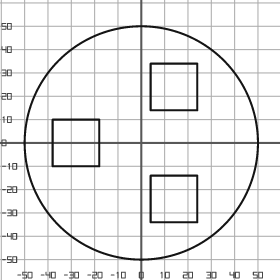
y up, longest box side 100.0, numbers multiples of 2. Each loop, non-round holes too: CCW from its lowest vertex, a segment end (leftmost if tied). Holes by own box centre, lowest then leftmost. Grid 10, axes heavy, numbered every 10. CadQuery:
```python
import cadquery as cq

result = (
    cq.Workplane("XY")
    .moveTo(0.0, 0.0)
    .circle(50.0)
    .moveTo(4.0, -34.0)
    .lineTo(24.0, -34.0)
    .lineTo(24.0, -14.0)
    .lineTo(4.0, -14.0)
    .close()
    .moveTo(-38.0, -10.0)
    .lineTo(-18.0, -10.0)
    .lineTo(-18.0, 10.0)
    .lineTo(-38.0, 10.0)
    .close()
    .moveTo(4.0, 14.0)
    .lineTo(24.0, 14.0)
    .lineTo(24.0, 34.0)
    .lineTo(4.0, 34.0)
    .close()
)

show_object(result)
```